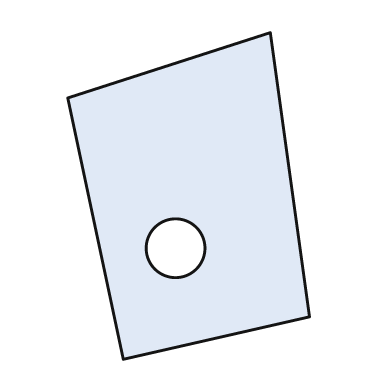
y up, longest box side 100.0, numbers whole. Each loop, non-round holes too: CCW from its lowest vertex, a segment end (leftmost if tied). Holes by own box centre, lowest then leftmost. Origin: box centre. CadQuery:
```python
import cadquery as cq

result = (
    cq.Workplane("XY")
    .moveTo(-20.0, -50.0)
    .lineTo(37.0, -37.0)
    .lineTo(25.0, 50.0)
    .lineTo(-37.0, 30.0)
    .close()
    .moveTo(-4.0, -16.0)
    .circle(9.0)
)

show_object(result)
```